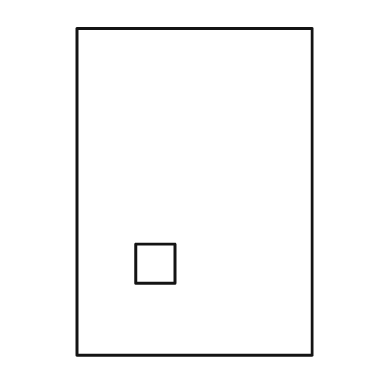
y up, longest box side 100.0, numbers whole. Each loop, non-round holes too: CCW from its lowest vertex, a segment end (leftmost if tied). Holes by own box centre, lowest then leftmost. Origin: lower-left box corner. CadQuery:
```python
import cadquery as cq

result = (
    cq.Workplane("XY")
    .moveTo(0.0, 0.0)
    .lineTo(72.0, 0.0)
    .lineTo(72.0, 100.0)
    .lineTo(0.0, 100.0)
    .close()
    .moveTo(18.0, 22.0)
    .lineTo(30.0, 22.0)
    .lineTo(30.0, 34.0)
    .lineTo(18.0, 34.0)
    .close()
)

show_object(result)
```